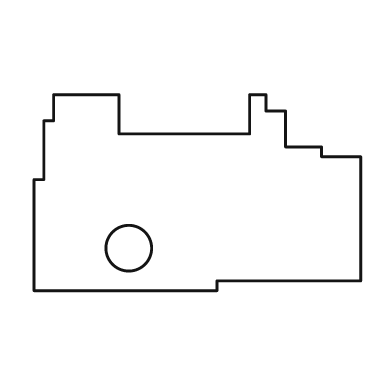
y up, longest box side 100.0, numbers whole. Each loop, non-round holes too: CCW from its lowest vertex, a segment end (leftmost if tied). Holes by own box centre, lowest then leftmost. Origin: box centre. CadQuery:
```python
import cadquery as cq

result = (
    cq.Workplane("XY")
    .moveTo(-50.0, -30.0)
    .lineTo(6.0, -30.0)
    .lineTo(6.0, -27.0)
    .lineTo(50.0, -27.0)
    .lineTo(50.0, 11.0)
    .lineTo(38.0, 11.0)
    .lineTo(38.0, 14.0)
    .lineTo(27.0, 14.0)
    .lineTo(27.0, 25.0)
    .lineTo(21.0, 25.0)
    .lineTo(21.0, 30.0)
    .lineTo(16.0, 30.0)
    .lineTo(16.0, 18.0)
    .lineTo(-24.0, 18.0)
    .lineTo(-24.0, 30.0)
    .lineTo(-44.0, 30.0)
    .lineTo(-44.0, 22.0)
    .lineTo(-47.0, 22.0)
    .lineTo(-47.0, 4.0)
    .lineTo(-50.0, 4.0)
    .close()
    .moveTo(-21.0, -17.0)
    .circle(7.0)
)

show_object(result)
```